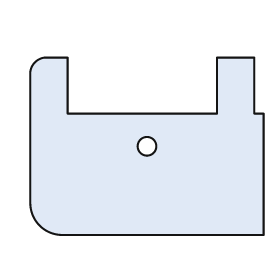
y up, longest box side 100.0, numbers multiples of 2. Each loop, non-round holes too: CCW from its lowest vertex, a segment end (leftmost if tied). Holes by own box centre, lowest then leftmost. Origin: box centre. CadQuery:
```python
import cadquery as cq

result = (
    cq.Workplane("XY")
    .moveTo(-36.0, -38.0)
    .lineTo(50.0, -38.0)
    .lineTo(50.0, 14.0)
    .lineTo(46.0, 14.0)
    .lineTo(46.0, 38.0)
    .lineTo(30.0, 38.0)
    .lineTo(30.0, 14.0)
    .lineTo(-34.0, 14.0)
    .lineTo(-34.0, 38.0)
    .lineTo(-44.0, 38.0)
    .threePointArc((-48.0, 36.0), (-50.0, 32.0))
    .lineTo(-50.0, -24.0)
    .threePointArc((-46.0, -34.0), (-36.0, -38.0))
    .close()
    .moveTo(0.0, 0.0)
    .circle(4.0)
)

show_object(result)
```